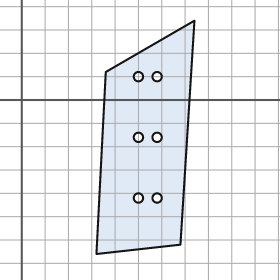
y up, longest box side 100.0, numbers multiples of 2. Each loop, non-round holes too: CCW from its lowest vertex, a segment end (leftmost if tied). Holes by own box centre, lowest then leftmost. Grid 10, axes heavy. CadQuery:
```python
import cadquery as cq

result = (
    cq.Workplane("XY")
    .moveTo(32.0, -66.0)
    .lineTo(68.0, -62.0)
    .lineTo(74.0, 34.0)
    .lineTo(36.0, 12.0)
    .close()
    .moveTo(50.0, -42.0)
    .circle(2.0)
    .moveTo(58.0, -42.0)
    .circle(2.0)
    .moveTo(50.0, -16.0)
    .circle(2.0)
    .moveTo(58.0, -16.0)
    .circle(2.0)
    .moveTo(50.0, 10.0)
    .circle(2.0)
    .moveTo(58.0, 10.0)
    .circle(2.0)
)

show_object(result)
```